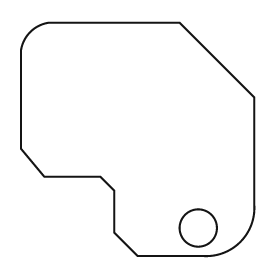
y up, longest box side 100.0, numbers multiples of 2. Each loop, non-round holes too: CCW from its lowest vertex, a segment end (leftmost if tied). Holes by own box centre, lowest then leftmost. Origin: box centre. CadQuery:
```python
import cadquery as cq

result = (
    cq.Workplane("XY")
    .moveTo(0.0, -50.0)
    .lineTo(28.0, -50.0)
    .threePointArc((44.0, -44.0), (50.0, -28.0))
    .lineTo(50.0, 18.0)
    .lineTo(18.0, 50.0)
    .lineTo(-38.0, 50.0)
    .threePointArc((-46.0, 46.0), (-50.0, 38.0))
    .lineTo(-50.0, -4.0)
    .lineTo(-40.0, -16.0)
    .lineTo(-16.0, -16.0)
    .lineTo(-10.0, -22.0)
    .lineTo(-10.0, -40.0)
    .close()
    .moveTo(26.0, -38.0)
    .circle(8.0)
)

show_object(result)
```